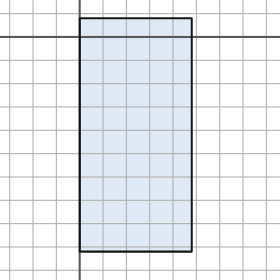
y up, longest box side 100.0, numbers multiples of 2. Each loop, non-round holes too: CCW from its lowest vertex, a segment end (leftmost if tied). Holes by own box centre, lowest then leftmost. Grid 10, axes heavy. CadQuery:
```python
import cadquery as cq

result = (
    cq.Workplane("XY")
    .moveTo(0.0, -92.0)
    .lineTo(48.0, -92.0)
    .lineTo(48.0, 8.0)
    .lineTo(0.0, 8.0)
    .close()
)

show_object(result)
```